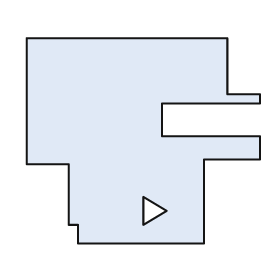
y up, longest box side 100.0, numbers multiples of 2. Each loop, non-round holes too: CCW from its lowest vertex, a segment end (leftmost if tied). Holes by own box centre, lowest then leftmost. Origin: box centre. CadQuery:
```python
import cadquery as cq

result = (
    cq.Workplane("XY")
    .moveTo(-28.0, -44.0)
    .lineTo(26.0, -44.0)
    .lineTo(26.0, -8.0)
    .lineTo(50.0, -8.0)
    .lineTo(50.0, 2.0)
    .lineTo(8.0, 2.0)
    .lineTo(8.0, 16.0)
    .lineTo(50.0, 16.0)
    .lineTo(50.0, 20.0)
    .lineTo(36.0, 20.0)
    .lineTo(36.0, 44.0)
    .lineTo(-50.0, 44.0)
    .lineTo(-50.0, -10.0)
    .lineTo(-32.0, -10.0)
    .lineTo(-32.0, -36.0)
    .lineTo(-28.0, -36.0)
    .close()
    .moveTo(0.0, -36.0)
    .lineTo(10.0, -30.0)
    .lineTo(0.0, -24.0)
    .close()
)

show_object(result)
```